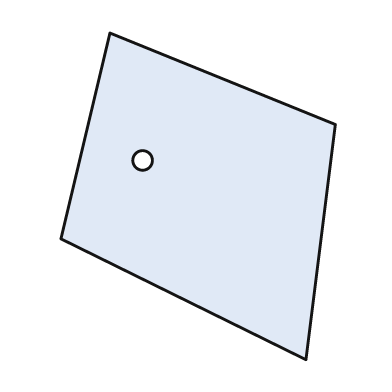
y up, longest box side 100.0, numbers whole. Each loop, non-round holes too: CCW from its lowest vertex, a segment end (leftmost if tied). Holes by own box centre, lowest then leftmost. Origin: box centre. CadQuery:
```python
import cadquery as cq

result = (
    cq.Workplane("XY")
    .moveTo(33.0, -50.0)
    .lineTo(42.0, 22.0)
    .lineTo(-27.0, 50.0)
    .lineTo(-42.0, -13.0)
    .close()
    .moveTo(-17.0, 11.0)
    .circle(3.0)
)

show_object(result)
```